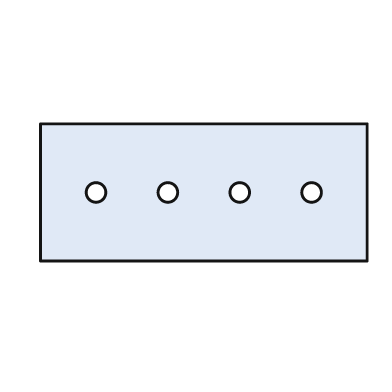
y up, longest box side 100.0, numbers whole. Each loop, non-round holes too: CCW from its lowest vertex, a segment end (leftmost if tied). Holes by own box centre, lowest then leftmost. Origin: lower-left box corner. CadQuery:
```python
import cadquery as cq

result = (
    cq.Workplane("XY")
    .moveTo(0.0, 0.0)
    .lineTo(100.0, 0.0)
    .lineTo(100.0, 42.0)
    .lineTo(0.0, 42.0)
    .close()
    .moveTo(17.0, 21.0)
    .circle(3.0)
    .moveTo(39.0, 21.0)
    .circle(3.0)
    .moveTo(61.0, 21.0)
    .circle(3.0)
    .moveTo(83.0, 21.0)
    .circle(3.0)
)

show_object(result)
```